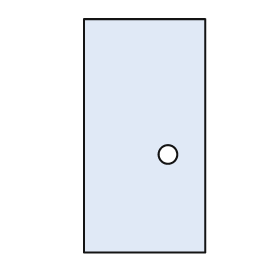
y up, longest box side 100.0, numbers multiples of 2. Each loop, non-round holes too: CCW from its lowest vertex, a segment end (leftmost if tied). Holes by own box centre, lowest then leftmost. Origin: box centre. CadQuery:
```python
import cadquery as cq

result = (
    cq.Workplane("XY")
    .moveTo(-26.0, -50.0)
    .lineTo(26.0, -50.0)
    .lineTo(26.0, 50.0)
    .lineTo(-26.0, 50.0)
    .close()
    .moveTo(10.0, -8.0)
    .circle(4.0)
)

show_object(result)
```